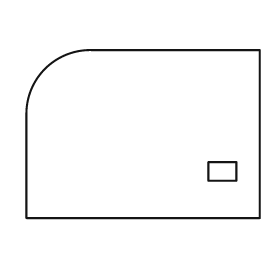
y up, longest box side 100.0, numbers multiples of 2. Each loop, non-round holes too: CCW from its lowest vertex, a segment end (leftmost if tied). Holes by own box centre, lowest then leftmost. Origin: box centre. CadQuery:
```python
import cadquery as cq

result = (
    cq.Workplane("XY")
    .moveTo(-50.0, -36.0)
    .lineTo(50.0, -36.0)
    .lineTo(50.0, 36.0)
    .lineTo(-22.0, 36.0)
    .threePointArc((-42.0, 28.0), (-50.0, 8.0))
    .close()
    .moveTo(28.0, -20.0)
    .lineTo(40.0, -20.0)
    .lineTo(40.0, -12.0)
    .lineTo(28.0, -12.0)
    .close()
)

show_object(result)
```